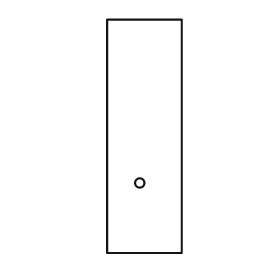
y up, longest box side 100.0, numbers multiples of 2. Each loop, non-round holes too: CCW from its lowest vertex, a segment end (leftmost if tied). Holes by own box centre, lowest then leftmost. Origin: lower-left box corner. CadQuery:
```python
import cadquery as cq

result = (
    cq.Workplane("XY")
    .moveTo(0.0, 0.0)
    .lineTo(32.0, 0.0)
    .lineTo(32.0, 100.0)
    .lineTo(0.0, 100.0)
    .close()
    .moveTo(14.0, 30.0)
    .circle(2.0)
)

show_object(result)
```